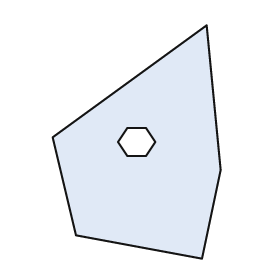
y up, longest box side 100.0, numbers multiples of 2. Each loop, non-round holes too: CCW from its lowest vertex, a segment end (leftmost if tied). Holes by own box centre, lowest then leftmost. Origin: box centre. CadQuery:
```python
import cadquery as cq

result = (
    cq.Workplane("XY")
    .moveTo(28.0, -50.0)
    .lineTo(36.0, -12.0)
    .lineTo(30.0, 50.0)
    .lineTo(-36.0, 2.0)
    .lineTo(-26.0, -40.0)
    .close()
    .moveTo(-4.0, -6.0)
    .lineTo(4.0, -6.0)
    .lineTo(8.0, 0.0)
    .lineTo(4.0, 6.0)
    .lineTo(-4.0, 6.0)
    .lineTo(-8.0, 0.0)
    .close()
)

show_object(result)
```